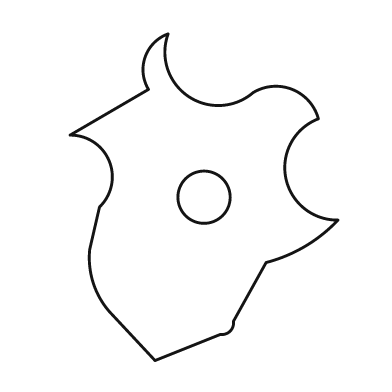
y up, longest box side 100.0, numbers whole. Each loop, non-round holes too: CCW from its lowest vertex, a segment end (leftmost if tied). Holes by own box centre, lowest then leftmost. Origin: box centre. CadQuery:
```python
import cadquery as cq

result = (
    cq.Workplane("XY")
    .moveTo(-15.0, -50.0)
    .lineTo(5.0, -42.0)
    .threePointArc((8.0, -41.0), (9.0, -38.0))
    .lineTo(19.0, -20.0)
    .threePointArc((31.0, -15.0), (41.0, -7.0))
    .threePointArc((25.0, 6.0), (35.0, 24.0))
    .threePointArc((27.0, 33.0), (15.0, 32.0))
    .threePointArc((-5.0, 31.0), (-11.0, 50.0))
    .threePointArc((-18.0, 43.0), (-17.0, 33.0))
    .lineTo(-41.0, 19.0)
    .threePointArc((-29.0, 11.0), (-32.0, -3.0))
    .lineTo(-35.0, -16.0)
    .threePointArc((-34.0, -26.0), (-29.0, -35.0))
    .close()
    .moveTo(0.0, 0.0)
    .circle(8.0)
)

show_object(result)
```